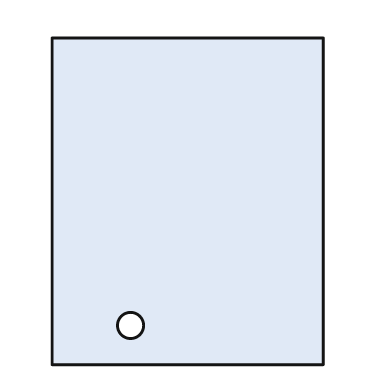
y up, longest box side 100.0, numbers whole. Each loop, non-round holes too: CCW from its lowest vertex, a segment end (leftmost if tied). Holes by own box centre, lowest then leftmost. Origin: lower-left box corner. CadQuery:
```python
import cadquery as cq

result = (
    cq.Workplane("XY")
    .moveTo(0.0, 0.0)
    .lineTo(83.0, 0.0)
    .lineTo(83.0, 100.0)
    .lineTo(0.0, 100.0)
    .close()
    .moveTo(24.0, 12.0)
    .circle(4.0)
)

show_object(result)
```